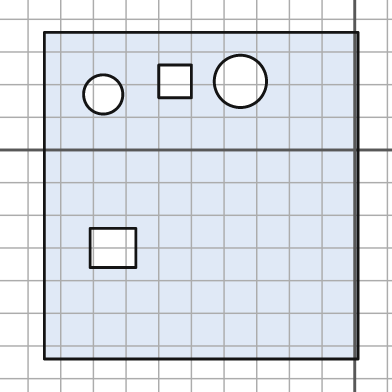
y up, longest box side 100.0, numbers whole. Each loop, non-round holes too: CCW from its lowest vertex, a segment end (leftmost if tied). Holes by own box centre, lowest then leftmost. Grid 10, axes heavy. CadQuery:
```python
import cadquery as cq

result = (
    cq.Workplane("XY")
    .moveTo(-95.0, -64.0)
    .lineTo(1.0, -64.0)
    .lineTo(1.0, 36.0)
    .lineTo(-95.0, 36.0)
    .close()
    .moveTo(-81.0, -36.0)
    .lineTo(-67.0, -36.0)
    .lineTo(-67.0, -24.0)
    .lineTo(-81.0, -24.0)
    .close()
    .moveTo(-77.0, 17.0)
    .circle(6.0)
    .moveTo(-60.0, 16.0)
    .lineTo(-50.0, 16.0)
    .lineTo(-50.0, 26.0)
    .lineTo(-60.0, 26.0)
    .close()
    .moveTo(-35.0, 21.0)
    .circle(8.0)
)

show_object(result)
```